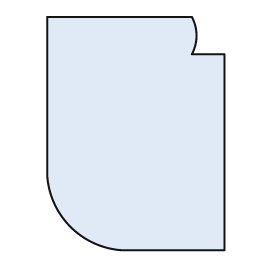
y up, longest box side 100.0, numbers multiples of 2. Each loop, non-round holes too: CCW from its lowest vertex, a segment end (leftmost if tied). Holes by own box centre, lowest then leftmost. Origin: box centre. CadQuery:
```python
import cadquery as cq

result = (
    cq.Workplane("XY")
    .moveTo(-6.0, -50.0)
    .lineTo(38.0, -50.0)
    .lineTo(38.0, 34.0)
    .lineTo(24.0, 34.0)
    .threePointArc((26.0, 42.0), (24.0, 50.0))
    .lineTo(-38.0, 50.0)
    .lineTo(-38.0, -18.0)
    .threePointArc((-28.0, -40.0), (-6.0, -50.0))
    .close()
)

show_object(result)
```